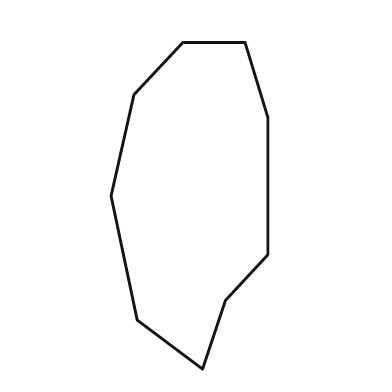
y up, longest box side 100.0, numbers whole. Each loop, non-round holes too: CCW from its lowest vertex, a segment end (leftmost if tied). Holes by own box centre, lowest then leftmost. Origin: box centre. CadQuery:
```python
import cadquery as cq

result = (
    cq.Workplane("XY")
    .moveTo(4.0, -50.0)
    .lineTo(11.0, -29.0)
    .lineTo(24.0, -15.0)
    .lineTo(24.0, 27.0)
    .lineTo(17.0, 50.0)
    .lineTo(-2.0, 50.0)
    .lineTo(-17.0, 34.0)
    .lineTo(-24.0, 3.0)
    .lineTo(-16.0, -35.0)
    .close()
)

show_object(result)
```